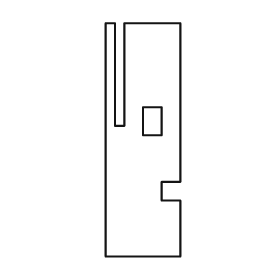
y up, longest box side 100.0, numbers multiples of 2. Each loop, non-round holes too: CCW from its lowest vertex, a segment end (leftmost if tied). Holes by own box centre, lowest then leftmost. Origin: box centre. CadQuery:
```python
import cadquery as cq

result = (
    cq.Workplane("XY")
    .moveTo(-16.0, -50.0)
    .lineTo(16.0, -50.0)
    .lineTo(16.0, -26.0)
    .lineTo(8.0, -26.0)
    .lineTo(8.0, -18.0)
    .lineTo(16.0, -18.0)
    .lineTo(16.0, 50.0)
    .lineTo(-8.0, 50.0)
    .lineTo(-8.0, 6.0)
    .lineTo(-12.0, 6.0)
    .lineTo(-12.0, 50.0)
    .lineTo(-16.0, 50.0)
    .close()
    .moveTo(0.0, 2.0)
    .lineTo(8.0, 2.0)
    .lineTo(8.0, 14.0)
    .lineTo(0.0, 14.0)
    .close()
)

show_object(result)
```